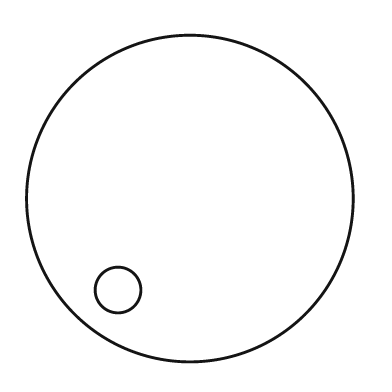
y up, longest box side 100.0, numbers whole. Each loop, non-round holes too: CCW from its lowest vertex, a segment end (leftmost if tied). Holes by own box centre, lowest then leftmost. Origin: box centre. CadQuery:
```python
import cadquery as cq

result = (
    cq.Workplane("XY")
    .moveTo(0.0, 0.0)
    .circle(50.0)
    .moveTo(-22.0, -28.0)
    .circle(7.0)
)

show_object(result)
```